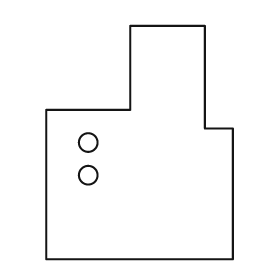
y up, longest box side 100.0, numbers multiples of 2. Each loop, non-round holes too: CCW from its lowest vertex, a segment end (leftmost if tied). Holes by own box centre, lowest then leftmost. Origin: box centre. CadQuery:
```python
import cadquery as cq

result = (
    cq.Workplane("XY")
    .moveTo(-40.0, -50.0)
    .lineTo(40.0, -50.0)
    .lineTo(40.0, 6.0)
    .lineTo(28.0, 6.0)
    .lineTo(28.0, 50.0)
    .lineTo(-4.0, 50.0)
    .lineTo(-4.0, 14.0)
    .lineTo(-40.0, 14.0)
    .close()
    .moveTo(-22.0, -14.0)
    .circle(4.0)
    .moveTo(-22.0, 0.0)
    .circle(4.0)
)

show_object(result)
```